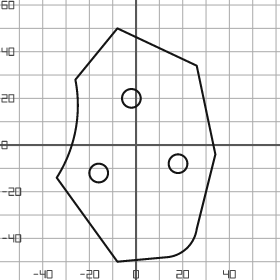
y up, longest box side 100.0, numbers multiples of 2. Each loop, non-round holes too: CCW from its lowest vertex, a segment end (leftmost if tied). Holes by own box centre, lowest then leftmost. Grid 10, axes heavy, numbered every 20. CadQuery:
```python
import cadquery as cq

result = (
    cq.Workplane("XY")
    .moveTo(-8.0, -50.0)
    .lineTo(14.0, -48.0)
    .threePointArc((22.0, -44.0), (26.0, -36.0))
    .lineTo(34.0, -4.0)
    .lineTo(26.0, 34.0)
    .lineTo(-8.0, 50.0)
    .lineTo(-26.0, 28.0)
    .threePointArc((-26.0, 6.0), (-34.0, -14.0))
    .close()
    .moveTo(-16.0, -12.0)
    .circle(4.0)
    .moveTo(18.0, -8.0)
    .circle(4.0)
    .moveTo(-2.0, 20.0)
    .circle(4.0)
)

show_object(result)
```